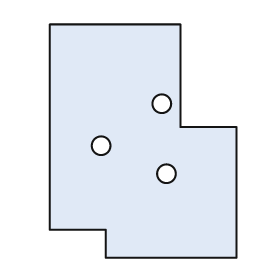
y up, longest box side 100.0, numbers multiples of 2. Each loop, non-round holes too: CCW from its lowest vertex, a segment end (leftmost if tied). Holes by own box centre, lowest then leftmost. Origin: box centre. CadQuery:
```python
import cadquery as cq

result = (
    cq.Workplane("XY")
    .moveTo(-16.0, -50.0)
    .lineTo(40.0, -50.0)
    .lineTo(40.0, 6.0)
    .lineTo(16.0, 6.0)
    .lineTo(16.0, 50.0)
    .lineTo(-40.0, 50.0)
    .lineTo(-40.0, -38.0)
    .lineTo(-16.0, -38.0)
    .close()
    .moveTo(10.0, -14.0)
    .circle(4.0)
    .moveTo(-18.0, -2.0)
    .circle(4.0)
    .moveTo(8.0, 16.0)
    .circle(4.0)
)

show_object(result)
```